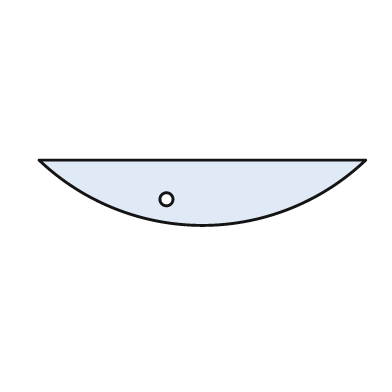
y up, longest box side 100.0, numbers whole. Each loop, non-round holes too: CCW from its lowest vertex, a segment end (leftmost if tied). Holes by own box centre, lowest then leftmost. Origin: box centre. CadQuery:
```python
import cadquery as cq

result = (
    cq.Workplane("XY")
    .moveTo(-50.0, 10.0)
    .threePointArc((0.0, -10.0), (50.0, 10.0))
    .close()
    .moveTo(-11.0, -2.0)
    .circle(2.0)
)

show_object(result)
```